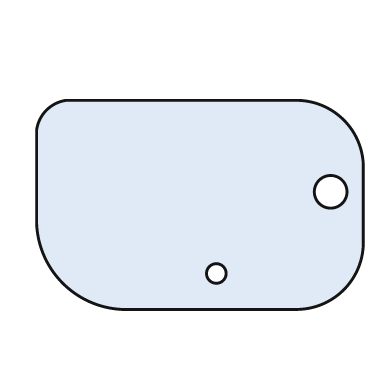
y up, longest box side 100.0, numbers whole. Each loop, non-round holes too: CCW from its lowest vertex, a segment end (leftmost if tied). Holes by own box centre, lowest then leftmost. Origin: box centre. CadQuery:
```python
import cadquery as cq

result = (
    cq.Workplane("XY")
    .moveTo(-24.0, -32.0)
    .lineTo(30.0, -32.0)
    .threePointArc((44.0, -26.0), (50.0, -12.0))
    .lineTo(50.0, 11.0)
    .threePointArc((44.0, 26.0), (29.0, 32.0))
    .lineTo(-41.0, 32.0)
    .threePointArc((-47.0, 29.0), (-50.0, 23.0))
    .lineTo(-50.0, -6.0)
    .threePointArc((-42.0, -24.0), (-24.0, -32.0))
    .close()
    .moveTo(5.0, -21.0)
    .circle(3.0)
    .moveTo(40.0, 4.0)
    .circle(5.0)
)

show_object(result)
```